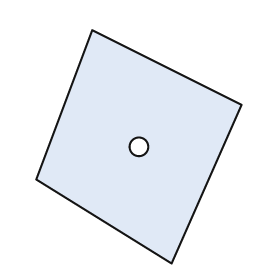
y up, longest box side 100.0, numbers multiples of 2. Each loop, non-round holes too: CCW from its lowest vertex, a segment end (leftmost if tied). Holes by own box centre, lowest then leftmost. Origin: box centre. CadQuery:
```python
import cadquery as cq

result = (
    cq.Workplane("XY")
    .moveTo(14.0, -50.0)
    .lineTo(44.0, 18.0)
    .lineTo(-20.0, 50.0)
    .lineTo(-44.0, -14.0)
    .close()
    .moveTo(0.0, 0.0)
    .circle(4.0)
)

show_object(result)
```